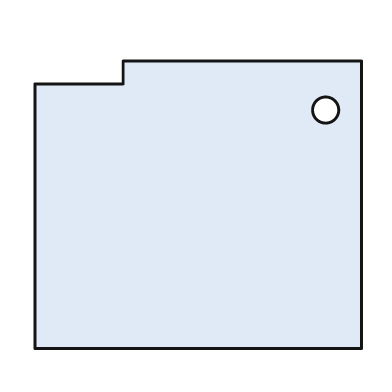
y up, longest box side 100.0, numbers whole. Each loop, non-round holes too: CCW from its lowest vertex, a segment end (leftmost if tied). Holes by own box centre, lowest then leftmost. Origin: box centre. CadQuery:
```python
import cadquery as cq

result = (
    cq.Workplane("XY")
    .moveTo(-50.0, -44.0)
    .lineTo(50.0, -44.0)
    .lineTo(50.0, 44.0)
    .lineTo(-23.0, 44.0)
    .lineTo(-23.0, 37.0)
    .lineTo(-50.0, 37.0)
    .close()
    .moveTo(39.0, 29.0)
    .circle(4.0)
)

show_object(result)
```